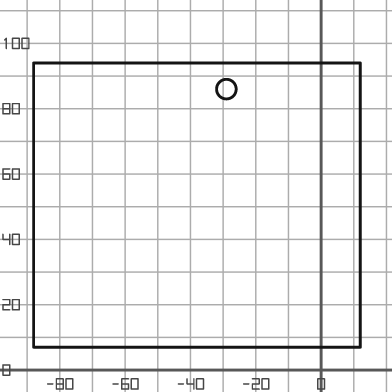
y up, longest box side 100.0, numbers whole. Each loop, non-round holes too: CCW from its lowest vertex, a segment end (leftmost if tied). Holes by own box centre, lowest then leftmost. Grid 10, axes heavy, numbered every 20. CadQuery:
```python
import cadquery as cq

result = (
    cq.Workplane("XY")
    .moveTo(-88.0, 7.0)
    .lineTo(12.0, 7.0)
    .lineTo(12.0, 94.0)
    .lineTo(-88.0, 94.0)
    .close()
    .moveTo(-29.0, 86.0)
    .circle(3.0)
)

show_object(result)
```